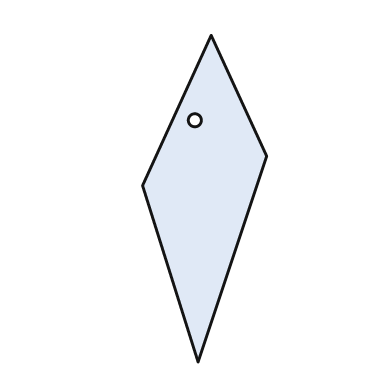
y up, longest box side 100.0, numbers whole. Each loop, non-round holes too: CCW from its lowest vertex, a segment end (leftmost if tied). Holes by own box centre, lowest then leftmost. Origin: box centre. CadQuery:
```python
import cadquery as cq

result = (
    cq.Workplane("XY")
    .moveTo(-2.0, -50.0)
    .lineTo(19.0, 13.0)
    .lineTo(2.0, 50.0)
    .lineTo(-19.0, 4.0)
    .close()
    .moveTo(-3.0, 24.0)
    .circle(2.0)
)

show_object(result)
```